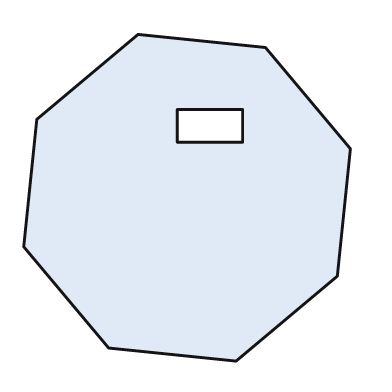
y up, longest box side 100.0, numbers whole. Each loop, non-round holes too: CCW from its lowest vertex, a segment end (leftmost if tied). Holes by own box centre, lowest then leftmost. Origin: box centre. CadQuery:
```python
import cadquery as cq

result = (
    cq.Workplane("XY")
    .moveTo(15.0, -50.0)
    .lineTo(46.0, -24.0)
    .lineTo(50.0, 15.0)
    .lineTo(24.0, 46.0)
    .lineTo(-15.0, 50.0)
    .lineTo(-46.0, 24.0)
    .lineTo(-50.0, -15.0)
    .lineTo(-24.0, -46.0)
    .close()
    .moveTo(-3.0, 17.0)
    .lineTo(17.0, 17.0)
    .lineTo(17.0, 27.0)
    .lineTo(-3.0, 27.0)
    .close()
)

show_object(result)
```